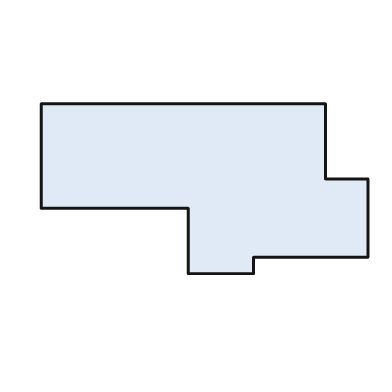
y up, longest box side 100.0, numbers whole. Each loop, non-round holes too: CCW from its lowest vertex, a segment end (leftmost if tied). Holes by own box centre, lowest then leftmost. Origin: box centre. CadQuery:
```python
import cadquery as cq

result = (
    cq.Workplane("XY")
    .moveTo(-5.0, -26.0)
    .lineTo(15.0, -26.0)
    .lineTo(15.0, -21.0)
    .lineTo(50.0, -21.0)
    .lineTo(50.0, 3.0)
    .lineTo(37.0, 3.0)
    .lineTo(37.0, 26.0)
    .lineTo(-50.0, 26.0)
    .lineTo(-50.0, -6.0)
    .lineTo(-5.0, -6.0)
    .close()
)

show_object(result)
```